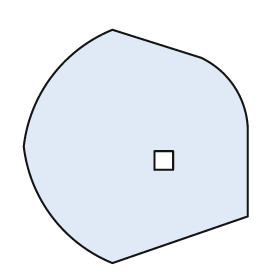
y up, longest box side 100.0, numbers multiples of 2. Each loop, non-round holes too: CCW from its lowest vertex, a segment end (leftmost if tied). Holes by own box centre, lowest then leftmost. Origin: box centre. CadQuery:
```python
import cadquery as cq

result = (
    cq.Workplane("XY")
    .moveTo(-10.0, -50.0)
    .lineTo(48.0, -30.0)
    .lineTo(48.0, 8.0)
    .threePointArc((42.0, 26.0), (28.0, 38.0))
    .lineTo(-10.0, 50.0)
    .threePointArc((-36.0, 30.0), (-48.0, 0.0))
    .threePointArc((-36.0, -30.0), (-10.0, -50.0))
    .close()
    .moveTo(8.0, -10.0)
    .lineTo(16.0, -10.0)
    .lineTo(16.0, -2.0)
    .lineTo(8.0, -2.0)
    .close()
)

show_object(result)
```